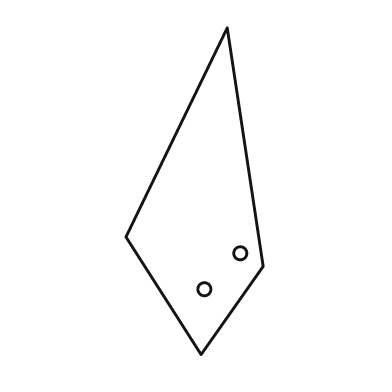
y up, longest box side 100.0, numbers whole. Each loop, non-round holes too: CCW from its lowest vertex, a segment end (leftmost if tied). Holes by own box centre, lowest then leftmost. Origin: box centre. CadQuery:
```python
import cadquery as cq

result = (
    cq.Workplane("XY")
    .moveTo(2.0, -50.0)
    .lineTo(21.0, -23.0)
    .lineTo(10.0, 50.0)
    .lineTo(-21.0, -14.0)
    .close()
    .moveTo(3.0, -30.0)
    .circle(2.0)
    .moveTo(14.0, -19.0)
    .circle(2.0)
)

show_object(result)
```